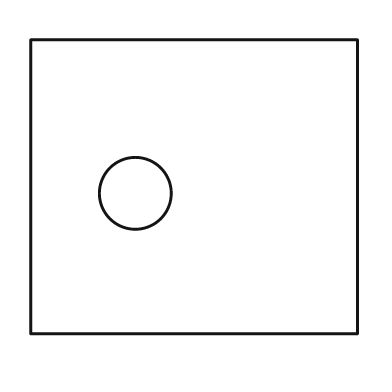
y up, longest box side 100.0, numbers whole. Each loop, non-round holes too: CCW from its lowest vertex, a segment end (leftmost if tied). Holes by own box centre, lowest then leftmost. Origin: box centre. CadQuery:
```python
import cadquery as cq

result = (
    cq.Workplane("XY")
    .moveTo(-50.0, -45.0)
    .lineTo(50.0, -45.0)
    .lineTo(50.0, 45.0)
    .lineTo(-50.0, 45.0)
    .close()
    .moveTo(-18.0, -2.0)
    .circle(11.0)
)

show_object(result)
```